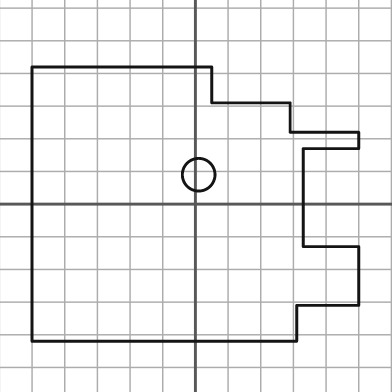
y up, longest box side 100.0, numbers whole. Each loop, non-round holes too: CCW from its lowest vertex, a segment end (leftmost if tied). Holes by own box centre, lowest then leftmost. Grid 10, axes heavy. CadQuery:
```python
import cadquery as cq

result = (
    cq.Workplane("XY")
    .moveTo(-50.0, -42.0)
    .lineTo(31.0, -42.0)
    .lineTo(31.0, -31.0)
    .lineTo(50.0, -31.0)
    .lineTo(50.0, -13.0)
    .lineTo(33.0, -13.0)
    .lineTo(33.0, 17.0)
    .lineTo(50.0, 17.0)
    .lineTo(50.0, 22.0)
    .lineTo(29.0, 22.0)
    .lineTo(29.0, 31.0)
    .lineTo(5.0, 31.0)
    .lineTo(5.0, 42.0)
    .lineTo(-50.0, 42.0)
    .close()
    .moveTo(1.0, 9.0)
    .circle(5.0)
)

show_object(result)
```